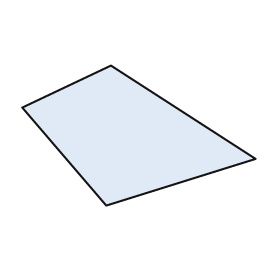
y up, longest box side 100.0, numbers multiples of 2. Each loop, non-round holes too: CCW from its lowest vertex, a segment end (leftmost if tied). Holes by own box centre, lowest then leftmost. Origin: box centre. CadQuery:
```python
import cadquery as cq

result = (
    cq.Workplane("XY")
    .moveTo(-14.0, -30.0)
    .lineTo(50.0, -10.0)
    .lineTo(-12.0, 30.0)
    .lineTo(-50.0, 12.0)
    .close()
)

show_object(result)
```